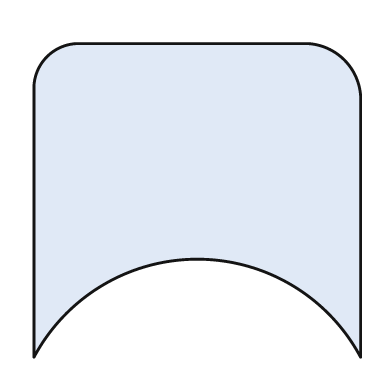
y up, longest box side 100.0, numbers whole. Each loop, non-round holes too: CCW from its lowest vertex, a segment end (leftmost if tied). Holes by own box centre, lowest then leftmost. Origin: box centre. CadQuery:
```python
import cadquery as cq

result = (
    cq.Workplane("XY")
    .moveTo(-50.0, -48.0)
    .threePointArc((0.0, -18.0), (50.0, -48.0))
    .lineTo(50.0, 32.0)
    .threePointArc((45.0, 43.0), (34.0, 48.0))
    .lineTo(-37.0, 48.0)
    .threePointArc((-46.0, 44.0), (-50.0, 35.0))
    .close()
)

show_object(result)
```